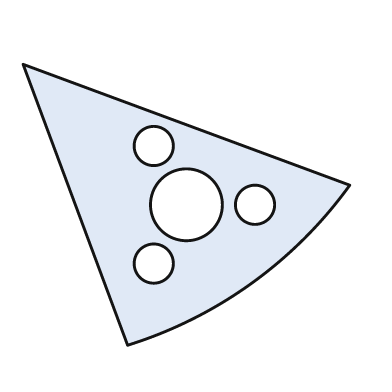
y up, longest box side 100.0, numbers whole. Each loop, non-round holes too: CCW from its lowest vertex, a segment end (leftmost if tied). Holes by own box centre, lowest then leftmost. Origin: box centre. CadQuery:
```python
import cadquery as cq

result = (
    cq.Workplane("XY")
    .moveTo(-18.0, -43.0)
    .threePointArc((20.0, -24.0), (50.0, 6.0))
    .lineTo(-50.0, 43.0)
    .close()
    .moveTo(-10.0, -18.0)
    .circle(6.0)
    .moveTo(0.0, 0.0)
    .circle(11.0)
    .moveTo(21.0, 0.0)
    .circle(6.0)
    .moveTo(-10.0, 18.0)
    .circle(6.0)
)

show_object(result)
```